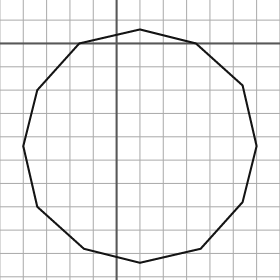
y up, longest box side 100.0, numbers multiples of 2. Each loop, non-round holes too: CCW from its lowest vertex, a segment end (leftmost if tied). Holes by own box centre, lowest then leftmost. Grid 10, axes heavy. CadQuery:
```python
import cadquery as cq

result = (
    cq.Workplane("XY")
    .moveTo(10.0, -94.0)
    .lineTo(36.0, -88.0)
    .lineTo(54.0, -68.0)
    .lineTo(60.0, -44.0)
    .lineTo(54.0, -18.0)
    .lineTo(34.0, 0.0)
    .lineTo(10.0, 6.0)
    .lineTo(-16.0, 0.0)
    .lineTo(-34.0, -20.0)
    .lineTo(-40.0, -44.0)
    .lineTo(-34.0, -70.0)
    .lineTo(-14.0, -88.0)
    .close()
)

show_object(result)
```